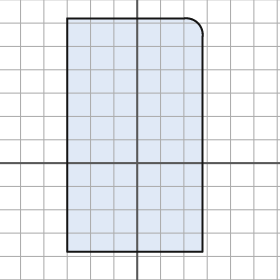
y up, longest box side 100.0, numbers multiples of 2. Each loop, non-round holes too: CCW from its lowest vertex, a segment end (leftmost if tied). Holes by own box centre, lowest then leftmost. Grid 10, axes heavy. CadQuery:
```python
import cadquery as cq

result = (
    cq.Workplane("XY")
    .moveTo(-30.0, -38.0)
    .lineTo(28.0, -38.0)
    .lineTo(28.0, 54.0)
    .threePointArc((26.0, 60.0), (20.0, 62.0))
    .lineTo(-30.0, 62.0)
    .close()
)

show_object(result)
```